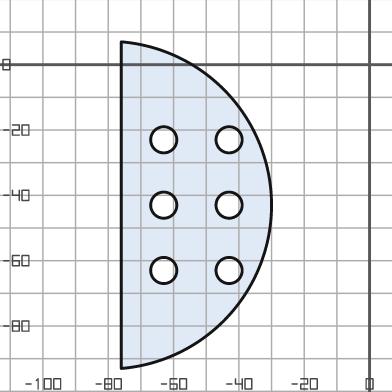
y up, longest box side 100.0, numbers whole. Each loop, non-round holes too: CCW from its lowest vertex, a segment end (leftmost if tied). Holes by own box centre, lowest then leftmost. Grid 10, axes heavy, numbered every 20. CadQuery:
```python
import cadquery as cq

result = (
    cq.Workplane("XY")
    .moveTo(-76.0, -93.0)
    .threePointArc((-30.0, -43.0), (-76.0, 7.0))
    .close()
    .moveTo(-63.0, -63.0)
    .circle(4.0)
    .moveTo(-43.0, -63.0)
    .circle(4.0)
    .moveTo(-63.0, -43.0)
    .circle(4.0)
    .moveTo(-43.0, -43.0)
    .circle(4.0)
    .moveTo(-63.0, -23.0)
    .circle(4.0)
    .moveTo(-43.0, -23.0)
    .circle(4.0)
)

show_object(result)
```